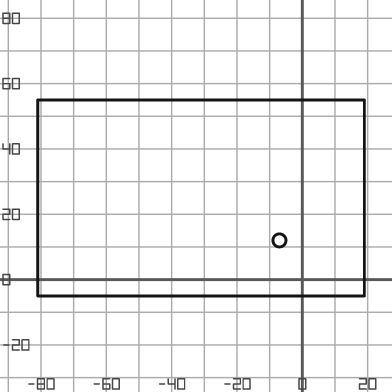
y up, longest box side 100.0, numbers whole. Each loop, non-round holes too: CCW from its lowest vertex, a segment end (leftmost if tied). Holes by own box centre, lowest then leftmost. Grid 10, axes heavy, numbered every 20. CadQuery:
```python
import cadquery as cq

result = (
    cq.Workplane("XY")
    .moveTo(-81.0, -5.0)
    .lineTo(19.0, -5.0)
    .lineTo(19.0, 55.0)
    .lineTo(-81.0, 55.0)
    .close()
    .moveTo(-7.0, 12.0)
    .circle(2.0)
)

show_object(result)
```